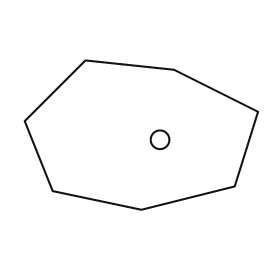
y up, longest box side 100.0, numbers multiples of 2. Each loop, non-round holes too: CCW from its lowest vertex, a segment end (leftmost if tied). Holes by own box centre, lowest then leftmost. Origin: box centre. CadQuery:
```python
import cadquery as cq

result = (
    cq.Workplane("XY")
    .moveTo(0.0, -32.0)
    .lineTo(40.0, -22.0)
    .lineTo(50.0, 10.0)
    .lineTo(14.0, 28.0)
    .lineTo(-24.0, 32.0)
    .lineTo(-50.0, 6.0)
    .lineTo(-38.0, -24.0)
    .close()
    .moveTo(8.0, -2.0)
    .circle(4.0)
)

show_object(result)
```